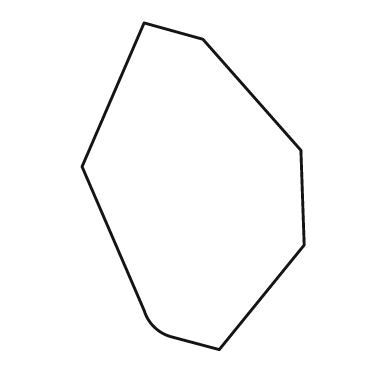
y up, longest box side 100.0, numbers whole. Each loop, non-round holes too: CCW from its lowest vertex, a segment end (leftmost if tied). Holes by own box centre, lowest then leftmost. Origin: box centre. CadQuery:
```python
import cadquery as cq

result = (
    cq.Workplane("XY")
    .moveTo(8.0, -50.0)
    .lineTo(34.0, -18.0)
    .lineTo(33.0, 11.0)
    .lineTo(3.0, 45.0)
    .lineTo(-15.0, 50.0)
    .lineTo(-34.0, 6.0)
    .lineTo(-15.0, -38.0)
    .threePointArc((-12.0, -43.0), (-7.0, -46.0))
    .close()
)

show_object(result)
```